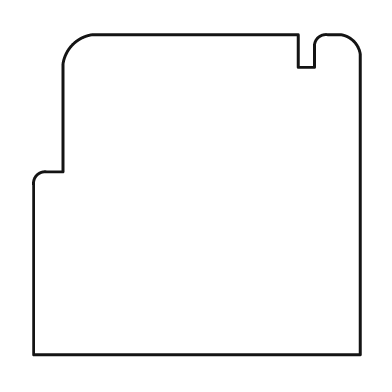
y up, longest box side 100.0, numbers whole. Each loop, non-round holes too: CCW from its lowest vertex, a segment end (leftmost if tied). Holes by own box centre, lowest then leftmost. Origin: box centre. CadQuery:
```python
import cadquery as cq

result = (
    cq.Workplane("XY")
    .moveTo(-50.0, -49.0)
    .lineTo(50.0, -49.0)
    .lineTo(50.0, 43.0)
    .threePointArc((48.0, 47.0), (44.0, 49.0))
    .lineTo(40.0, 49.0)
    .threePointArc((37.0, 48.0), (36.0, 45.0))
    .lineTo(36.0, 39.0)
    .lineTo(31.0, 39.0)
    .lineTo(31.0, 49.0)
    .lineTo(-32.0, 49.0)
    .threePointArc((-38.0, 46.0), (-41.0, 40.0))
    .lineTo(-41.0, 7.0)
    .lineTo(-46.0, 7.0)
    .threePointArc((-49.0, 6.0), (-50.0, 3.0))
    .close()
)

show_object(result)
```